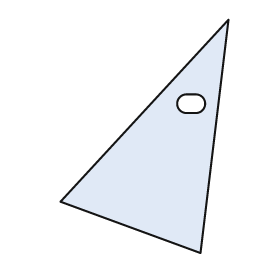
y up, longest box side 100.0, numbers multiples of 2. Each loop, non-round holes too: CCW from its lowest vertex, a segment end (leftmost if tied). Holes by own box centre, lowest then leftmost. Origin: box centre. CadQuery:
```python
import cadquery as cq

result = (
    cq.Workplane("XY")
    .moveTo(24.0, -50.0)
    .lineTo(36.0, 50.0)
    .lineTo(-36.0, -28.0)
    .close()
    .moveTo(18.0, 10.0)
    .lineTo(22.0, 10.0)
    .threePointArc((26.0, 14.0), (22.0, 18.0))
    .lineTo(18.0, 18.0)
    .threePointArc((14.0, 14.0), (18.0, 10.0))
    .close()
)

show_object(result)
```